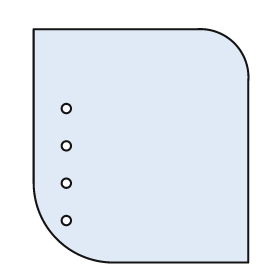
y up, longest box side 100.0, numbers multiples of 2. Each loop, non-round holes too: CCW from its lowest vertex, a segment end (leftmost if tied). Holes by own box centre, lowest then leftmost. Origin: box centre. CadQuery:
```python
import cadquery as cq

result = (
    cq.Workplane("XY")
    .moveTo(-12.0, -50.0)
    .lineTo(46.0, -50.0)
    .lineTo(46.0, 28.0)
    .threePointArc((40.0, 44.0), (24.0, 50.0))
    .lineTo(-46.0, 50.0)
    .lineTo(-46.0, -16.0)
    .threePointArc((-36.0, -40.0), (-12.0, -50.0))
    .close()
    .moveTo(-32.0, -32.0)
    .circle(2.0)
    .moveTo(-32.0, -16.0)
    .circle(2.0)
    .moveTo(-32.0, 0.0)
    .circle(2.0)
    .moveTo(-32.0, 16.0)
    .circle(2.0)
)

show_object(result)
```